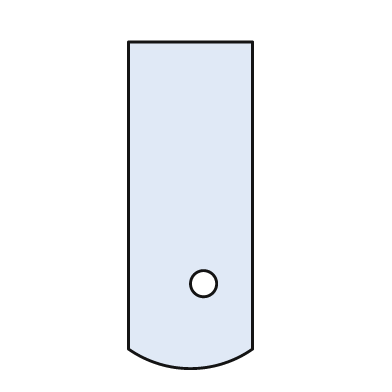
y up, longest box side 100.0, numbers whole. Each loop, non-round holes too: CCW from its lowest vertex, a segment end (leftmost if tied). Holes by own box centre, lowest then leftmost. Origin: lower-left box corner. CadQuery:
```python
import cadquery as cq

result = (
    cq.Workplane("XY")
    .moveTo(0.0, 6.0)
    .threePointArc((19.0, 0.0), (38.0, 6.0))
    .lineTo(38.0, 100.0)
    .lineTo(0.0, 100.0)
    .close()
    .moveTo(23.0, 26.0)
    .circle(4.0)
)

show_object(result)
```